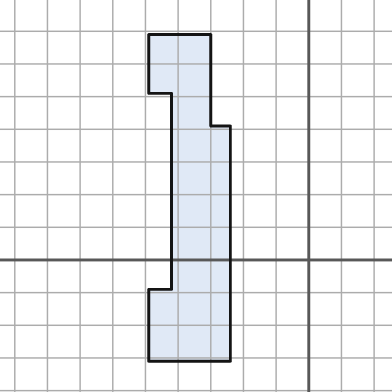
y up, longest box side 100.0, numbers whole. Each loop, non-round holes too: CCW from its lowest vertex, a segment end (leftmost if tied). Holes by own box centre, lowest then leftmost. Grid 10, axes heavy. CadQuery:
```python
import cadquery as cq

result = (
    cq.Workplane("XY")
    .moveTo(-49.0, -31.0)
    .lineTo(-24.0, -31.0)
    .lineTo(-24.0, 41.0)
    .lineTo(-30.0, 41.0)
    .lineTo(-30.0, 69.0)
    .lineTo(-49.0, 69.0)
    .lineTo(-49.0, 51.0)
    .lineTo(-42.0, 51.0)
    .lineTo(-42.0, -9.0)
    .lineTo(-49.0, -9.0)
    .close()
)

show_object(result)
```